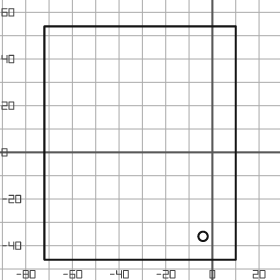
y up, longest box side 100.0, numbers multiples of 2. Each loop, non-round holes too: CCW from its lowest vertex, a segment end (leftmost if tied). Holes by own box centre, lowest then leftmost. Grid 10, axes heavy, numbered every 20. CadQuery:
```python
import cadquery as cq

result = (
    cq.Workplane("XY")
    .moveTo(-72.0, -46.0)
    .lineTo(10.0, -46.0)
    .lineTo(10.0, 54.0)
    .lineTo(-72.0, 54.0)
    .close()
    .moveTo(-4.0, -36.0)
    .circle(2.0)
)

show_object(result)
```